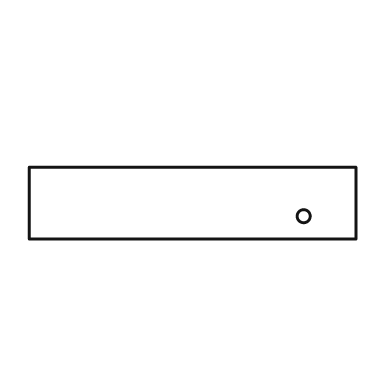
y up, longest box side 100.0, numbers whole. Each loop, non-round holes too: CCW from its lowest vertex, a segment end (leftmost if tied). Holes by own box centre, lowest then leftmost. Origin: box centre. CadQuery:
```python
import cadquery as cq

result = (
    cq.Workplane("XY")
    .moveTo(-50.0, -11.0)
    .lineTo(50.0, -11.0)
    .lineTo(50.0, 11.0)
    .lineTo(-50.0, 11.0)
    .close()
    .moveTo(34.0, -4.0)
    .circle(2.0)
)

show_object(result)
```